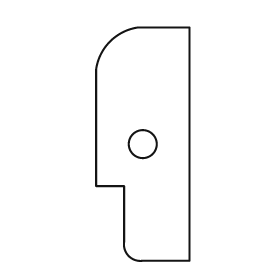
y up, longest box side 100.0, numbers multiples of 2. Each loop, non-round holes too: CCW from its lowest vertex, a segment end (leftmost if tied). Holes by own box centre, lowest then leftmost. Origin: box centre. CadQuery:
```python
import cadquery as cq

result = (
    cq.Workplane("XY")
    .moveTo(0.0, -50.0)
    .lineTo(20.0, -50.0)
    .lineTo(20.0, 50.0)
    .lineTo(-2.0, 50.0)
    .threePointArc((-14.0, 44.0), (-20.0, 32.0))
    .lineTo(-20.0, -18.0)
    .lineTo(-8.0, -18.0)
    .lineTo(-8.0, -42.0)
    .threePointArc((-6.0, -48.0), (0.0, -50.0))
    .close()
    .moveTo(0.0, 0.0)
    .circle(6.0)
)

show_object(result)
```